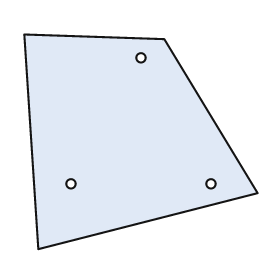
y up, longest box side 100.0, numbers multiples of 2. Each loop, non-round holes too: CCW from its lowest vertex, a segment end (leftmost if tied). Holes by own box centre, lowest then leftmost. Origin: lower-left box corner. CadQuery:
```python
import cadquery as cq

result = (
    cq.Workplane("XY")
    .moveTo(6.0, 0.0)
    .lineTo(100.0, 24.0)
    .lineTo(60.0, 90.0)
    .lineTo(0.0, 92.0)
    .close()
    .moveTo(20.0, 28.0)
    .circle(2.0)
    .moveTo(80.0, 28.0)
    .circle(2.0)
    .moveTo(50.0, 82.0)
    .circle(2.0)
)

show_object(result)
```